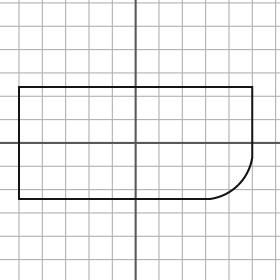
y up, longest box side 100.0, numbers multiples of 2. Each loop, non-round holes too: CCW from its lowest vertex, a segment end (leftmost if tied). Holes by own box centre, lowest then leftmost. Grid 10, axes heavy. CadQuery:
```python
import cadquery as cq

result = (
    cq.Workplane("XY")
    .moveTo(-50.0, -24.0)
    .lineTo(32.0, -24.0)
    .threePointArc((44.0, -18.0), (50.0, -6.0))
    .lineTo(50.0, 24.0)
    .lineTo(-50.0, 24.0)
    .close()
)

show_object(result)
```